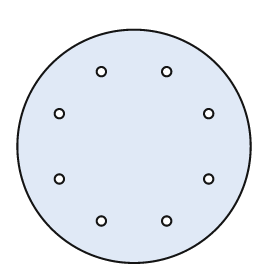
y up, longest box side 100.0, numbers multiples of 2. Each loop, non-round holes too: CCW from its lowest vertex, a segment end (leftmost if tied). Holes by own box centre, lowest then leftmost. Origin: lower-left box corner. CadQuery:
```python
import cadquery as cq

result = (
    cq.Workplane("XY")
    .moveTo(50.0, 50.0)
    .circle(50.0)
    .moveTo(36.0, 18.0)
    .circle(2.0)
    .moveTo(64.0, 18.0)
    .circle(2.0)
    .moveTo(18.0, 36.0)
    .circle(2.0)
    .moveTo(82.0, 36.0)
    .circle(2.0)
    .moveTo(18.0, 64.0)
    .circle(2.0)
    .moveTo(82.0, 64.0)
    .circle(2.0)
    .moveTo(36.0, 82.0)
    .circle(2.0)
    .moveTo(64.0, 82.0)
    .circle(2.0)
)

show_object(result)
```